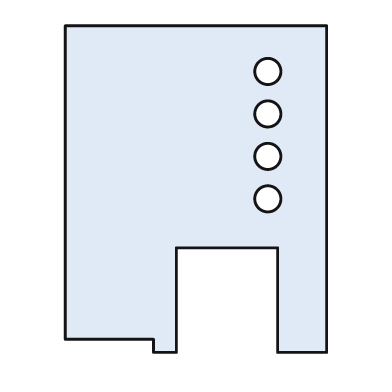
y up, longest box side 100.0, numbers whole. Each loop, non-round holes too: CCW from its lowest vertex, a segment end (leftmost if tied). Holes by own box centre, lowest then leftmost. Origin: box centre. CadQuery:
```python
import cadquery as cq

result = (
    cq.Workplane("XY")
    .moveTo(-13.0, -50.0)
    .lineTo(-6.0, -50.0)
    .lineTo(-6.0, -18.0)
    .lineTo(25.0, -18.0)
    .lineTo(25.0, -50.0)
    .lineTo(40.0, -50.0)
    .lineTo(40.0, 50.0)
    .lineTo(-40.0, 50.0)
    .lineTo(-40.0, -46.0)
    .lineTo(-13.0, -46.0)
    .close()
    .moveTo(22.0, -3.0)
    .circle(4.0)
    .moveTo(22.0, 10.0)
    .circle(4.0)
    .moveTo(22.0, 23.0)
    .circle(4.0)
    .moveTo(22.0, 36.0)
    .circle(4.0)
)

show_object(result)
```